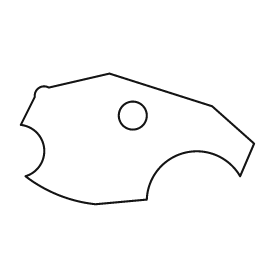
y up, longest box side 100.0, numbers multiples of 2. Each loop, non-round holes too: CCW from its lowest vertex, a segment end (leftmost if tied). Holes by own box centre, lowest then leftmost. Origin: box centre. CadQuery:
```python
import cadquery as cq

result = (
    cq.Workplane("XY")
    .moveTo(-18.0, -28.0)
    .lineTo(4.0, -26.0)
    .threePointArc((20.0, -6.0), (44.0, -16.0))
    .lineTo(50.0, -2.0)
    .lineTo(32.0, 14.0)
    .lineTo(-12.0, 28.0)
    .lineTo(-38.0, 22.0)
    .threePointArc((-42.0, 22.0), (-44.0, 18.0))
    .lineTo(-50.0, 6.0)
    .threePointArc((-40.0, -4.0), (-48.0, -16.0))
    .threePointArc((-34.0, -24.0), (-18.0, -28.0))
    .close()
    .moveTo(-2.0, 10.0)
    .circle(6.0)
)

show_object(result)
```